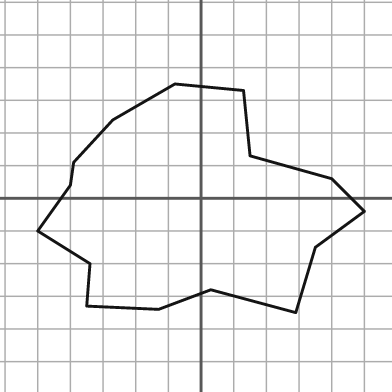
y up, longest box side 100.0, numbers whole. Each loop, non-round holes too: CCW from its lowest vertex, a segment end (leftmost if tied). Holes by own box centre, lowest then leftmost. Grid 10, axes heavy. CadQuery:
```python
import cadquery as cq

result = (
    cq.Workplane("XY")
    .moveTo(29.0, -35.0)
    .lineTo(35.0, -15.0)
    .lineTo(50.0, -4.0)
    .lineTo(40.0, 6.0)
    .lineTo(15.0, 13.0)
    .lineTo(13.0, 33.0)
    .lineTo(-8.0, 35.0)
    .lineTo(-27.0, 24.0)
    .lineTo(-39.0, 11.0)
    .lineTo(-40.0, 4.0)
    .lineTo(-50.0, -10.0)
    .lineTo(-34.0, -20.0)
    .lineTo(-35.0, -33.0)
    .lineTo(-13.0, -34.0)
    .lineTo(3.0, -28.0)
    .close()
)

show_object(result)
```